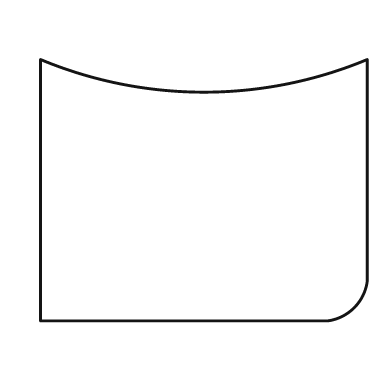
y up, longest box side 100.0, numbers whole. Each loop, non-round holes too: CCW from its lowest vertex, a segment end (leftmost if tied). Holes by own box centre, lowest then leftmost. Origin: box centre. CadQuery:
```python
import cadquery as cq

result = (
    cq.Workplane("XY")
    .moveTo(-50.0, -40.0)
    .lineTo(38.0, -40.0)
    .threePointArc((46.0, -36.0), (50.0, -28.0))
    .lineTo(50.0, 40.0)
    .threePointArc((0.0, 30.0), (-50.0, 40.0))
    .close()
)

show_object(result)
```